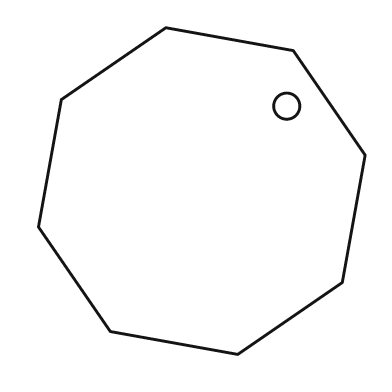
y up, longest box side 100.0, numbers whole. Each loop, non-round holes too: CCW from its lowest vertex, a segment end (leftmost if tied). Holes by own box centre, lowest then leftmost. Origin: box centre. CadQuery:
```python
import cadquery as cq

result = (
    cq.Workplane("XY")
    .moveTo(11.0, -50.0)
    .lineTo(43.0, -28.0)
    .lineTo(50.0, 11.0)
    .lineTo(28.0, 43.0)
    .lineTo(-11.0, 50.0)
    .lineTo(-43.0, 28.0)
    .lineTo(-50.0, -11.0)
    .lineTo(-28.0, -43.0)
    .close()
    .moveTo(26.0, 26.0)
    .circle(4.0)
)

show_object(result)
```